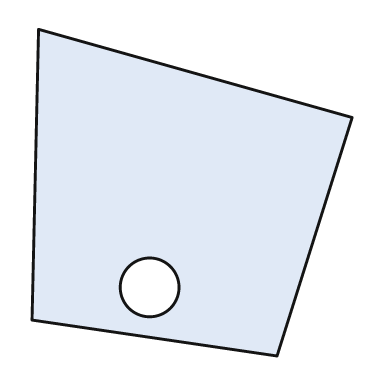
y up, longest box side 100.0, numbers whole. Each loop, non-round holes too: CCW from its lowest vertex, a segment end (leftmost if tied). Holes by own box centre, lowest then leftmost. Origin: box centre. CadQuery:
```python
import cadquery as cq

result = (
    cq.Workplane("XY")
    .moveTo(26.0, -50.0)
    .lineTo(49.0, 23.0)
    .lineTo(-47.0, 50.0)
    .lineTo(-49.0, -39.0)
    .close()
    .moveTo(-13.0, -29.0)
    .circle(9.0)
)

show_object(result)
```